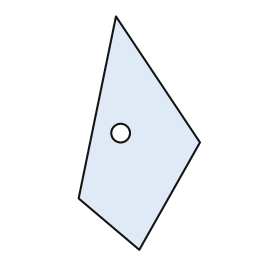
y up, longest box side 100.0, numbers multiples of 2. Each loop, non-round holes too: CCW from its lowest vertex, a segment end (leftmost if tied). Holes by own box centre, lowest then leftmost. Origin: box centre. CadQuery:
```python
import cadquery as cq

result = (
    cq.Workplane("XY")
    .moveTo(0.0, -50.0)
    .lineTo(26.0, -4.0)
    .lineTo(-10.0, 50.0)
    .lineTo(-26.0, -28.0)
    .close()
    .moveTo(-8.0, 0.0)
    .circle(4.0)
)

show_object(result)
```